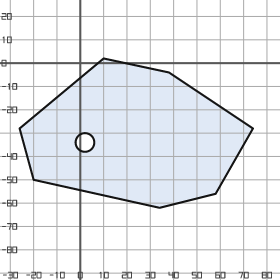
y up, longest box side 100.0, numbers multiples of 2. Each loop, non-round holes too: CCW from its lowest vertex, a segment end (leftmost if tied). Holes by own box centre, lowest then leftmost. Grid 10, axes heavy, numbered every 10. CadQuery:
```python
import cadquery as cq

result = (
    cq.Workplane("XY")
    .moveTo(34.0, -62.0)
    .lineTo(58.0, -56.0)
    .lineTo(74.0, -28.0)
    .lineTo(38.0, -4.0)
    .lineTo(10.0, 2.0)
    .lineTo(-26.0, -28.0)
    .lineTo(-20.0, -50.0)
    .close()
    .moveTo(2.0, -34.0)
    .circle(4.0)
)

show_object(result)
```